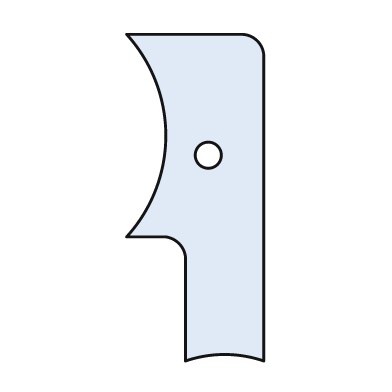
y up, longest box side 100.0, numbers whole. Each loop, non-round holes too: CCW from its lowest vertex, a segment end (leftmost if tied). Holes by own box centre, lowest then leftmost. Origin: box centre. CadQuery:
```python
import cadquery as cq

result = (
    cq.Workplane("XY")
    .moveTo(-3.0, -50.0)
    .threePointArc((9.0, -48.0), (21.0, -50.0))
    .lineTo(21.0, 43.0)
    .threePointArc((19.0, 48.0), (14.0, 50.0))
    .lineTo(-21.0, 50.0)
    .threePointArc((-9.0, 19.0), (-21.0, -12.0))
    .lineTo(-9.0, -12.0)
    .threePointArc((-5.0, -14.0), (-3.0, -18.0))
    .close()
    .moveTo(4.0, 13.0)
    .circle(4.0)
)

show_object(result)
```